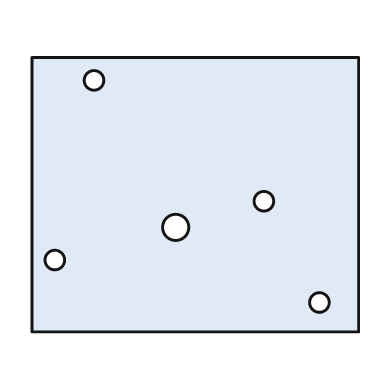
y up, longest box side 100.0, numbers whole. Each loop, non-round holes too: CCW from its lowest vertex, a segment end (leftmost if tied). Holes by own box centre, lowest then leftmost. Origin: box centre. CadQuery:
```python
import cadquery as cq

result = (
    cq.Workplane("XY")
    .moveTo(-50.0, -42.0)
    .lineTo(50.0, -42.0)
    .lineTo(50.0, 42.0)
    .lineTo(-50.0, 42.0)
    .close()
    .moveTo(38.0, -33.0)
    .circle(3.0)
    .moveTo(-43.0, -20.0)
    .circle(3.0)
    .moveTo(-6.0, -10.0)
    .circle(4.0)
    .moveTo(21.0, -2.0)
    .circle(3.0)
    .moveTo(-31.0, 35.0)
    .circle(3.0)
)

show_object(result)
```